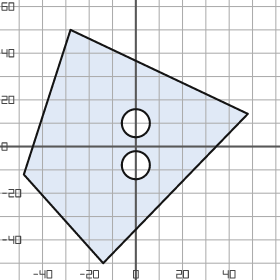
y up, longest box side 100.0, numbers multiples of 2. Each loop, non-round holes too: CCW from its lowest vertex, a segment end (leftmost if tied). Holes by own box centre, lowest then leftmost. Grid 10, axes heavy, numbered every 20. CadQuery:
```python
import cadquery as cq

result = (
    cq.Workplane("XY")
    .moveTo(-14.0, -50.0)
    .lineTo(48.0, 14.0)
    .lineTo(-28.0, 50.0)
    .lineTo(-48.0, -12.0)
    .close()
    .moveTo(0.0, -8.0)
    .circle(6.0)
    .moveTo(0.0, 10.0)
    .circle(6.0)
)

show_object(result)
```